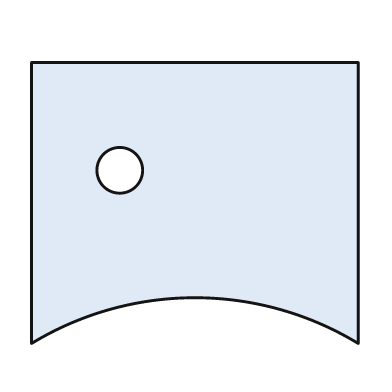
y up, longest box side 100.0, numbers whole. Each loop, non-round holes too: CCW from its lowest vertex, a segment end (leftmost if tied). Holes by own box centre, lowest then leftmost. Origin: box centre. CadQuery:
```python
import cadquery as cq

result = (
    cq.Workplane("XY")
    .moveTo(-50.0, -43.0)
    .threePointArc((0.0, -29.0), (50.0, -43.0))
    .lineTo(50.0, 43.0)
    .lineTo(-50.0, 43.0)
    .close()
    .moveTo(-23.0, 10.0)
    .circle(7.0)
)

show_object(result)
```